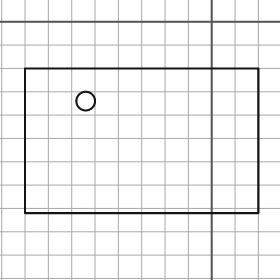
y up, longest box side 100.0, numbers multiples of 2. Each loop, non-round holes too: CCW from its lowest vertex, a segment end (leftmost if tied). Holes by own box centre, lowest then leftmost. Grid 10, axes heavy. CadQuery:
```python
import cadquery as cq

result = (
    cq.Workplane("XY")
    .moveTo(-80.0, -82.0)
    .lineTo(20.0, -82.0)
    .lineTo(20.0, -20.0)
    .lineTo(-80.0, -20.0)
    .close()
    .moveTo(-54.0, -34.0)
    .circle(4.0)
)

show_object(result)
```